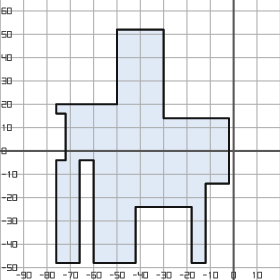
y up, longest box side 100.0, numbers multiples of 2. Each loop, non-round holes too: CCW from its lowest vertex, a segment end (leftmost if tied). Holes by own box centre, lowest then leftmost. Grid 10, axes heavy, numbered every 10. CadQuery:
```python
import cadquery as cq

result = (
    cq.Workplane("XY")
    .moveTo(-76.0, -48.0)
    .lineTo(-66.0, -48.0)
    .lineTo(-66.0, -4.0)
    .lineTo(-60.0, -4.0)
    .lineTo(-60.0, -48.0)
    .lineTo(-42.0, -48.0)
    .lineTo(-42.0, -24.0)
    .lineTo(-18.0, -24.0)
    .lineTo(-18.0, -48.0)
    .lineTo(-12.0, -48.0)
    .lineTo(-12.0, -14.0)
    .lineTo(-2.0, -14.0)
    .lineTo(-2.0, 14.0)
    .lineTo(-30.0, 14.0)
    .lineTo(-30.0, 52.0)
    .lineTo(-50.0, 52.0)
    .lineTo(-50.0, 20.0)
    .lineTo(-76.0, 20.0)
    .lineTo(-76.0, 16.0)
    .lineTo(-72.0, 16.0)
    .lineTo(-72.0, -4.0)
    .lineTo(-76.0, -4.0)
    .close()
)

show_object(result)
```